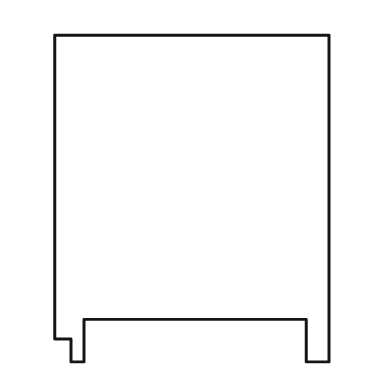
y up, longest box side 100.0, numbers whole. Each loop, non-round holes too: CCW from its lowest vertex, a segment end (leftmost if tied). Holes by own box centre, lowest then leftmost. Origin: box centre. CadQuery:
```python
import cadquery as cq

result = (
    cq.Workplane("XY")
    .moveTo(-37.0, -50.0)
    .lineTo(-33.0, -50.0)
    .lineTo(-33.0, -37.0)
    .lineTo(35.0, -37.0)
    .lineTo(35.0, -50.0)
    .lineTo(42.0, -50.0)
    .lineTo(42.0, 50.0)
    .lineTo(-42.0, 50.0)
    .lineTo(-42.0, -43.0)
    .lineTo(-37.0, -43.0)
    .close()
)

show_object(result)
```